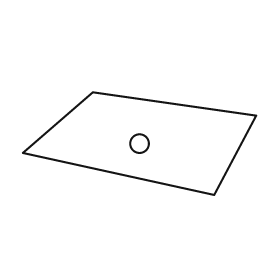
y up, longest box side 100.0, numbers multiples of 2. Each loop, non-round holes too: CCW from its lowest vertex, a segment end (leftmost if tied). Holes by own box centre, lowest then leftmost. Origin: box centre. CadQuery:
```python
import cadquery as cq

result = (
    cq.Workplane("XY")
    .moveTo(32.0, -22.0)
    .lineTo(50.0, 12.0)
    .lineTo(-20.0, 22.0)
    .lineTo(-50.0, -4.0)
    .close()
    .moveTo(0.0, 0.0)
    .circle(4.0)
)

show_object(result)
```